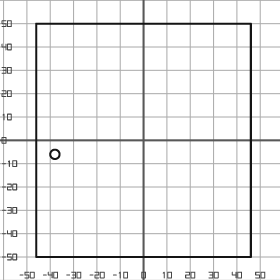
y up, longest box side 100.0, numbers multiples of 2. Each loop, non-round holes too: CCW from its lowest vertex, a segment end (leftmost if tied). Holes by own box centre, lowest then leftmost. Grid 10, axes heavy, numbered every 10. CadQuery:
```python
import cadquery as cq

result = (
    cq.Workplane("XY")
    .moveTo(-46.0, -50.0)
    .lineTo(46.0, -50.0)
    .lineTo(46.0, 50.0)
    .lineTo(-46.0, 50.0)
    .close()
    .moveTo(-38.0, -6.0)
    .circle(2.0)
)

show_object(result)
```